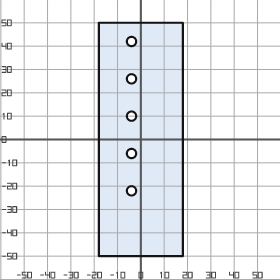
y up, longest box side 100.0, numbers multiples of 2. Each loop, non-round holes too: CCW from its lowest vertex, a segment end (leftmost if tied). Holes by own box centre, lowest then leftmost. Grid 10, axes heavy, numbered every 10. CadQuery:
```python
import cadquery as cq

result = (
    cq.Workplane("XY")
    .moveTo(-18.0, -50.0)
    .lineTo(18.0, -50.0)
    .lineTo(18.0, 50.0)
    .lineTo(-18.0, 50.0)
    .close()
    .moveTo(-4.0, -22.0)
    .circle(2.0)
    .moveTo(-4.0, -6.0)
    .circle(2.0)
    .moveTo(-4.0, 10.0)
    .circle(2.0)
    .moveTo(-4.0, 26.0)
    .circle(2.0)
    .moveTo(-4.0, 42.0)
    .circle(2.0)
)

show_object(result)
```